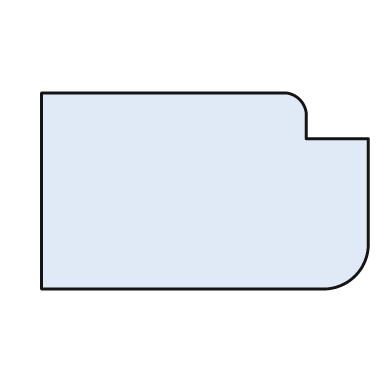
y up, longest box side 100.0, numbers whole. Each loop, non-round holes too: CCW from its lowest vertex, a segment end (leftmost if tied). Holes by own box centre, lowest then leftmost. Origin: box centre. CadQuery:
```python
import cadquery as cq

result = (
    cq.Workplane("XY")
    .moveTo(-50.0, -30.0)
    .lineTo(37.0, -30.0)
    .threePointArc((46.0, -26.0), (50.0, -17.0))
    .lineTo(50.0, 16.0)
    .lineTo(31.0, 16.0)
    .lineTo(31.0, 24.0)
    .threePointArc((29.0, 28.0), (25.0, 30.0))
    .lineTo(-50.0, 30.0)
    .close()
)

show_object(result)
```